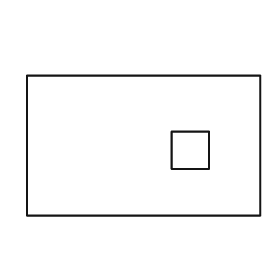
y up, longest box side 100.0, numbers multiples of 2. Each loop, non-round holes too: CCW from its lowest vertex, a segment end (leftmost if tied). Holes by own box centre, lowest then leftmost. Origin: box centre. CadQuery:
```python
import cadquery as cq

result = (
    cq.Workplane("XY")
    .moveTo(-50.0, -30.0)
    .lineTo(50.0, -30.0)
    .lineTo(50.0, 30.0)
    .lineTo(-50.0, 30.0)
    .close()
    .moveTo(12.0, -10.0)
    .lineTo(28.0, -10.0)
    .lineTo(28.0, 6.0)
    .lineTo(12.0, 6.0)
    .close()
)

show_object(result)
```